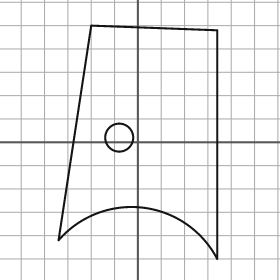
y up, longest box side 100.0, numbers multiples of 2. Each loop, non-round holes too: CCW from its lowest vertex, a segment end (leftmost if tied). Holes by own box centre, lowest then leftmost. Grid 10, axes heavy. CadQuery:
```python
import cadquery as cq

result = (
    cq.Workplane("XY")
    .moveTo(34.0, -50.0)
    .lineTo(34.0, 48.0)
    .lineTo(-20.0, 50.0)
    .lineTo(-34.0, -42.0)
    .threePointArc((2.0, -28.0), (34.0, -50.0))
    .close()
    .moveTo(-8.0, 2.0)
    .circle(6.0)
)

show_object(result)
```